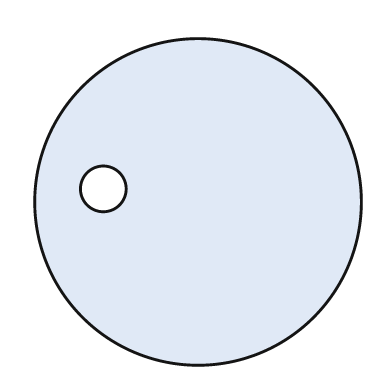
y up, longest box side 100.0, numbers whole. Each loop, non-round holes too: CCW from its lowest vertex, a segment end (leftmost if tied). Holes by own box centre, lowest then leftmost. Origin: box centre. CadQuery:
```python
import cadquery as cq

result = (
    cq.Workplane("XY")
    .moveTo(0.0, 0.0)
    .circle(50.0)
    .moveTo(-29.0, 4.0)
    .circle(7.0)
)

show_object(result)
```